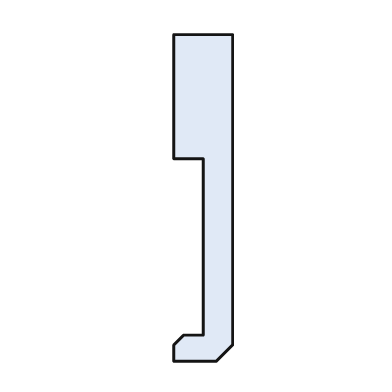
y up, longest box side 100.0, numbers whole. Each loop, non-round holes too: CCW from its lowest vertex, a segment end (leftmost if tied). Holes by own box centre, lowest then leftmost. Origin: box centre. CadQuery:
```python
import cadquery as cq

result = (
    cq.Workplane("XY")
    .moveTo(-9.0, -50.0)
    .lineTo(4.0, -50.0)
    .lineTo(9.0, -45.0)
    .lineTo(9.0, 50.0)
    .lineTo(-9.0, 50.0)
    .lineTo(-9.0, 12.0)
    .lineTo(0.0, 12.0)
    .lineTo(0.0, -42.0)
    .lineTo(-6.0, -42.0)
    .lineTo(-9.0, -45.0)
    .close()
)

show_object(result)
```